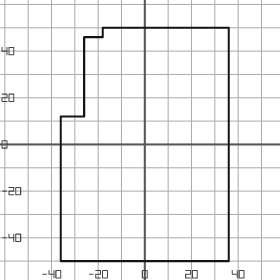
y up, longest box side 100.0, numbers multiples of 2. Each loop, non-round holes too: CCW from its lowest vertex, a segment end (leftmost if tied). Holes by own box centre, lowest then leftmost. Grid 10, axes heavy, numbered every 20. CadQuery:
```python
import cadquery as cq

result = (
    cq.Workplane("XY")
    .moveTo(-36.0, -50.0)
    .lineTo(36.0, -50.0)
    .lineTo(36.0, 50.0)
    .lineTo(-18.0, 50.0)
    .lineTo(-18.0, 46.0)
    .lineTo(-26.0, 46.0)
    .lineTo(-26.0, 12.0)
    .lineTo(-36.0, 12.0)
    .close()
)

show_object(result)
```